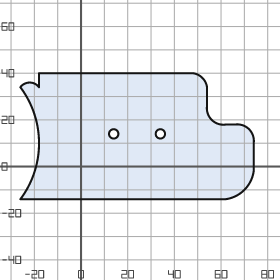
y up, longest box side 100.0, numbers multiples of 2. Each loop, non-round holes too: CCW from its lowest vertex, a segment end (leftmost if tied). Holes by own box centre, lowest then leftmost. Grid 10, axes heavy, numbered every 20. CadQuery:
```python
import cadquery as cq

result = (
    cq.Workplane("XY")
    .moveTo(-26.0, -14.0)
    .lineTo(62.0, -14.0)
    .threePointArc((70.0, -10.0), (74.0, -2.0))
    .lineTo(74.0, 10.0)
    .threePointArc((72.0, 16.0), (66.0, 18.0))
    .lineTo(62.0, 18.0)
    .threePointArc((56.0, 20.0), (54.0, 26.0))
    .lineTo(54.0, 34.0)
    .threePointArc((52.0, 38.0), (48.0, 40.0))
    .lineTo(-18.0, 40.0)
    .lineTo(-18.0, 34.0)
    .threePointArc((-22.0, 36.0), (-26.0, 34.0))
    .threePointArc((-18.0, 10.0), (-26.0, -14.0))
    .close()
    .moveTo(14.0, 14.0)
    .circle(2.0)
    .moveTo(34.0, 14.0)
    .circle(2.0)
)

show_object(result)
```